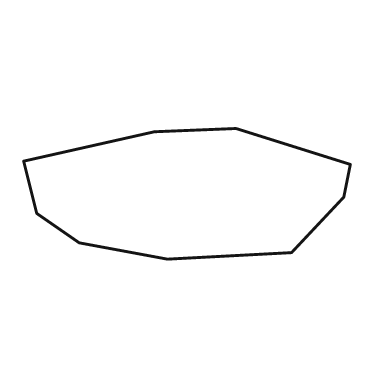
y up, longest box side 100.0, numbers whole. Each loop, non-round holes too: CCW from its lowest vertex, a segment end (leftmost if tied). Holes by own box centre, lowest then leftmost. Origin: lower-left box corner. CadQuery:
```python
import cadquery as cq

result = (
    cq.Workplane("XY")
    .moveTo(44.0, 0.0)
    .lineTo(82.0, 2.0)
    .lineTo(98.0, 19.0)
    .lineTo(100.0, 29.0)
    .lineTo(65.0, 40.0)
    .lineTo(40.0, 39.0)
    .lineTo(0.0, 30.0)
    .lineTo(4.0, 14.0)
    .lineTo(17.0, 5.0)
    .close()
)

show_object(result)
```